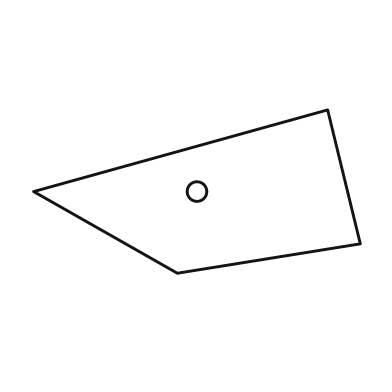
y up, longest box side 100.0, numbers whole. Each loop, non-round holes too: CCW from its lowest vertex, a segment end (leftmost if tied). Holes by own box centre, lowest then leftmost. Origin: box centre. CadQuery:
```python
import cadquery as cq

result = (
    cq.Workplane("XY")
    .moveTo(-6.0, -25.0)
    .lineTo(50.0, -16.0)
    .lineTo(40.0, 25.0)
    .lineTo(-50.0, 0.0)
    .close()
    .moveTo(0.0, 0.0)
    .circle(3.0)
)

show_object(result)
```